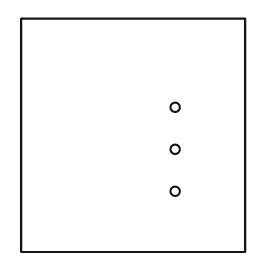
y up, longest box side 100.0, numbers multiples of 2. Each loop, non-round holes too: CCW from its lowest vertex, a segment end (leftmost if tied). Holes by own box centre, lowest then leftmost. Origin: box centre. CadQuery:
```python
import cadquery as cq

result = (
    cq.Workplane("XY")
    .moveTo(-48.0, -50.0)
    .lineTo(48.0, -50.0)
    .lineTo(48.0, 50.0)
    .lineTo(-48.0, 50.0)
    .close()
    .moveTo(18.0, -24.0)
    .circle(2.0)
    .moveTo(18.0, -6.0)
    .circle(2.0)
    .moveTo(18.0, 12.0)
    .circle(2.0)
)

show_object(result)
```